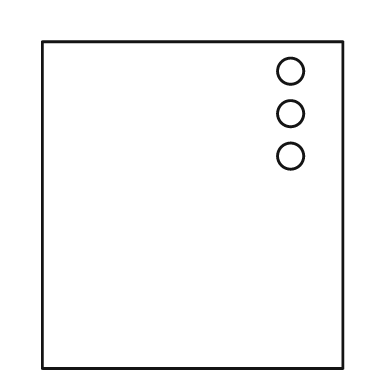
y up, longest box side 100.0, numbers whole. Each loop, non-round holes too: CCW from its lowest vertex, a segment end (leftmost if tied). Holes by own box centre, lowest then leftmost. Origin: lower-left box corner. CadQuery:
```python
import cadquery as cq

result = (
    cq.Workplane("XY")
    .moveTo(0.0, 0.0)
    .lineTo(92.0, 0.0)
    .lineTo(92.0, 100.0)
    .lineTo(0.0, 100.0)
    .close()
    .moveTo(76.0, 65.0)
    .circle(4.0)
    .moveTo(76.0, 78.0)
    .circle(4.0)
    .moveTo(76.0, 91.0)
    .circle(4.0)
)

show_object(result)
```